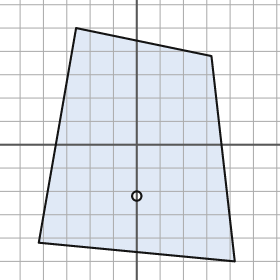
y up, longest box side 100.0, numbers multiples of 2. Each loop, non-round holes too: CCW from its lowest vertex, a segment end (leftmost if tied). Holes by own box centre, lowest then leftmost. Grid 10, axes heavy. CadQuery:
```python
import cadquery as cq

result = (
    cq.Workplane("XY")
    .moveTo(42.0, -50.0)
    .lineTo(32.0, 38.0)
    .lineTo(-26.0, 50.0)
    .lineTo(-42.0, -42.0)
    .close()
    .moveTo(0.0, -22.0)
    .circle(2.0)
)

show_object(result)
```